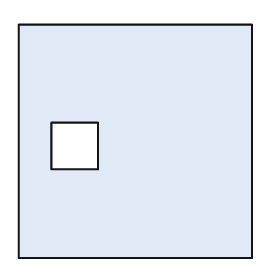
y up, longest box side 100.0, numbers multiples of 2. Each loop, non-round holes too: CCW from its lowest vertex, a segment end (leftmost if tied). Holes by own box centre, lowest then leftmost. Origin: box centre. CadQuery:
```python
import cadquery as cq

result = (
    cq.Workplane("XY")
    .moveTo(-50.0, -50.0)
    .lineTo(50.0, -50.0)
    .lineTo(50.0, 50.0)
    .lineTo(-50.0, 50.0)
    .close()
    .moveTo(-36.0, -12.0)
    .lineTo(-16.0, -12.0)
    .lineTo(-16.0, 8.0)
    .lineTo(-36.0, 8.0)
    .close()
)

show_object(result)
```